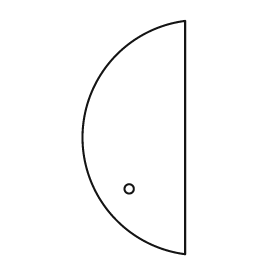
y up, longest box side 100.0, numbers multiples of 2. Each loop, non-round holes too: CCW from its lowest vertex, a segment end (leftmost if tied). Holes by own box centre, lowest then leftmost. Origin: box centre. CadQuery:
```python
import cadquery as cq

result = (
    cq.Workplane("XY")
    .moveTo(22.0, -50.0)
    .lineTo(22.0, 50.0)
    .threePointArc((-22.0, 0.0), (22.0, -50.0))
    .close()
    .moveTo(-2.0, -22.0)
    .circle(2.0)
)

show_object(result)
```